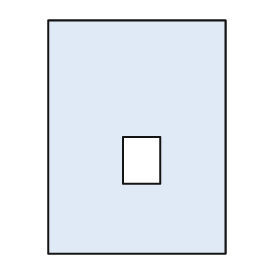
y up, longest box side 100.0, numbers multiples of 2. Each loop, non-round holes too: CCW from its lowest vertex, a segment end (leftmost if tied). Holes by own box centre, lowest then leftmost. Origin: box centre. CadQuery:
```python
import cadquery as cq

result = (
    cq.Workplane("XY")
    .moveTo(-38.0, -50.0)
    .lineTo(38.0, -50.0)
    .lineTo(38.0, 50.0)
    .lineTo(-38.0, 50.0)
    .close()
    .moveTo(-6.0, -20.0)
    .lineTo(10.0, -20.0)
    .lineTo(10.0, 0.0)
    .lineTo(-6.0, 0.0)
    .close()
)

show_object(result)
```